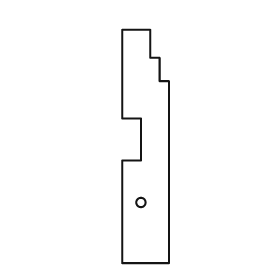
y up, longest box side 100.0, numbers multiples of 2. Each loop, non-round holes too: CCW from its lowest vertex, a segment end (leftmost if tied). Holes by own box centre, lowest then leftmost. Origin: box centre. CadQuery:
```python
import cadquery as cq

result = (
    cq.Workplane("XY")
    .moveTo(-10.0, -50.0)
    .lineTo(10.0, -50.0)
    .lineTo(10.0, 28.0)
    .lineTo(6.0, 28.0)
    .lineTo(6.0, 38.0)
    .lineTo(2.0, 38.0)
    .lineTo(2.0, 50.0)
    .lineTo(-10.0, 50.0)
    .lineTo(-10.0, 12.0)
    .lineTo(-2.0, 12.0)
    .lineTo(-2.0, -6.0)
    .lineTo(-10.0, -6.0)
    .close()
    .moveTo(-2.0, -24.0)
    .circle(2.0)
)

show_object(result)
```